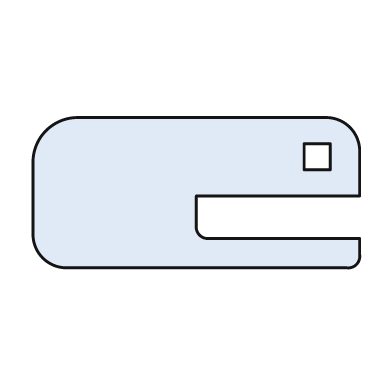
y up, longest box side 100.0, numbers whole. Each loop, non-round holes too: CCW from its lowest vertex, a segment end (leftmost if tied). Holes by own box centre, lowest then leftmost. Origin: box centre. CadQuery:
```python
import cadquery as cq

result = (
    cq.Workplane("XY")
    .moveTo(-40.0, -23.0)
    .lineTo(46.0, -23.0)
    .threePointArc((49.0, -22.0), (50.0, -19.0))
    .lineTo(50.0, -14.0)
    .lineTo(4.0, -14.0)
    .threePointArc((1.0, -13.0), (0.0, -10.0))
    .lineTo(0.0, -1.0)
    .lineTo(50.0, -1.0)
    .lineTo(50.0, 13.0)
    .threePointArc((47.0, 20.0), (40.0, 23.0))
    .lineTo(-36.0, 23.0)
    .threePointArc((-46.0, 19.0), (-50.0, 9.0))
    .lineTo(-50.0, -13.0)
    .threePointArc((-47.0, -20.0), (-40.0, -23.0))
    .close()
    .moveTo(33.0, 7.0)
    .lineTo(41.0, 7.0)
    .lineTo(41.0, 15.0)
    .lineTo(33.0, 15.0)
    .close()
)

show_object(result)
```